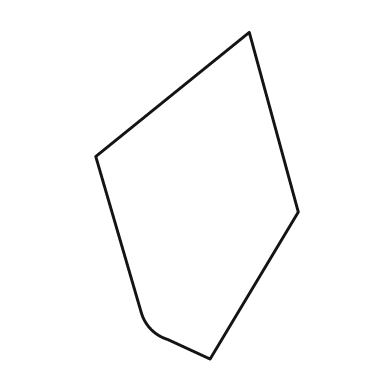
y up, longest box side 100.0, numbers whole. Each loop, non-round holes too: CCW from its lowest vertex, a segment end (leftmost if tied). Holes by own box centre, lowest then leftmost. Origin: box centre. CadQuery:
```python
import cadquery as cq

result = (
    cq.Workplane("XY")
    .moveTo(4.0, -50.0)
    .lineTo(31.0, -5.0)
    .lineTo(16.0, 50.0)
    .lineTo(-31.0, 12.0)
    .lineTo(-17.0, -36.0)
    .threePointArc((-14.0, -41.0), (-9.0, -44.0))
    .close()
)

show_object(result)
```